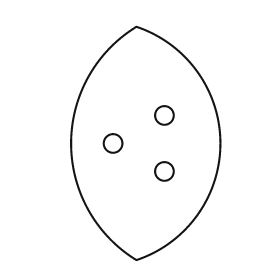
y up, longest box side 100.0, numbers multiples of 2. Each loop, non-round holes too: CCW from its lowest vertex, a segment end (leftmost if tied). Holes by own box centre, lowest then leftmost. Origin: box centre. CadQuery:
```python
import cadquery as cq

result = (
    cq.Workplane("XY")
    .moveTo(-4.0, -50.0)
    .threePointArc((32.0, 0.0), (-4.0, 50.0))
    .threePointArc((-32.0, 0.0), (-4.0, -50.0))
    .close()
    .moveTo(8.0, -12.0)
    .circle(4.0)
    .moveTo(-14.0, 0.0)
    .circle(4.0)
    .moveTo(8.0, 12.0)
    .circle(4.0)
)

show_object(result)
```